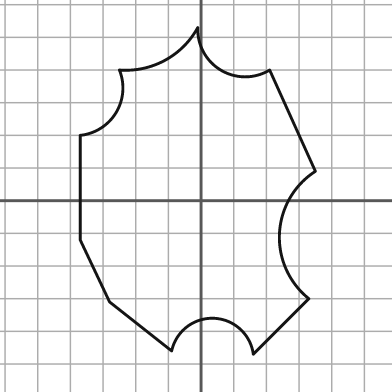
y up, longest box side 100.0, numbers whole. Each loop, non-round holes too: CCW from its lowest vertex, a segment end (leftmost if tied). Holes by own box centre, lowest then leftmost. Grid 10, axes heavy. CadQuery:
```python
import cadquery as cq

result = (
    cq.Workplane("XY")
    .moveTo(16.0, -47.0)
    .lineTo(33.0, -30.0)
    .threePointArc((24.0, -10.0), (35.0, 9.0))
    .lineTo(21.0, 40.0)
    .threePointArc((6.0, 40.0), (-1.0, 53.0))
    .threePointArc((-11.0, 43.0), (-25.0, 40.0))
    .threePointArc((-26.0, 27.0), (-37.0, 20.0))
    .lineTo(-37.0, -12.0)
    .lineTo(-28.0, -31.0)
    .lineTo(-9.0, -46.0)
    .threePointArc((4.0, -36.0), (16.0, -47.0))
    .close()
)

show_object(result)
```